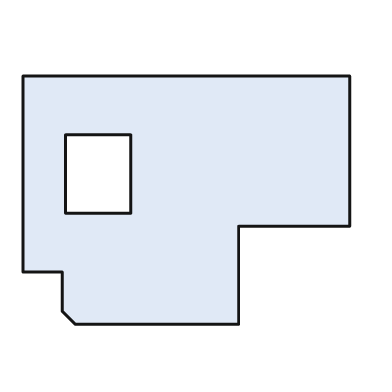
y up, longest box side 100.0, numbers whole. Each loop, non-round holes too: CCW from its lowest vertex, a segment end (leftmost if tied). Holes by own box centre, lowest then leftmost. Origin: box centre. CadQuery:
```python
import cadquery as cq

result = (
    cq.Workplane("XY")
    .moveTo(-34.0, -38.0)
    .lineTo(16.0, -38.0)
    .lineTo(16.0, -8.0)
    .lineTo(50.0, -8.0)
    .lineTo(50.0, 38.0)
    .lineTo(-50.0, 38.0)
    .lineTo(-50.0, -22.0)
    .lineTo(-38.0, -22.0)
    .lineTo(-38.0, -34.0)
    .close()
    .moveTo(-37.0, -4.0)
    .lineTo(-17.0, -4.0)
    .lineTo(-17.0, 20.0)
    .lineTo(-37.0, 20.0)
    .close()
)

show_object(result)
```